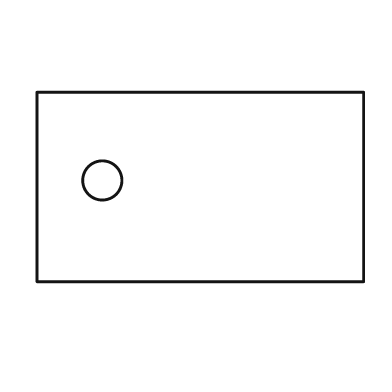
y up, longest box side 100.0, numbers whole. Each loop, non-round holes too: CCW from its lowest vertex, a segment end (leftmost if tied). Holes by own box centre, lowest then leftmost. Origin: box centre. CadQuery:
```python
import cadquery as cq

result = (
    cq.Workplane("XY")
    .moveTo(-50.0, -29.0)
    .lineTo(50.0, -29.0)
    .lineTo(50.0, 29.0)
    .lineTo(-50.0, 29.0)
    .close()
    .moveTo(-30.0, 2.0)
    .circle(6.0)
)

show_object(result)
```